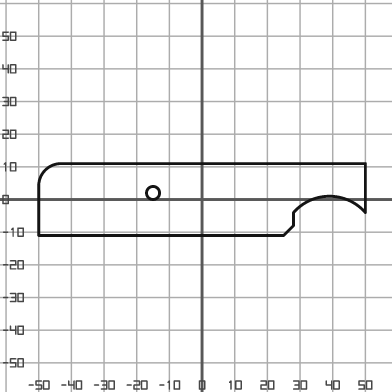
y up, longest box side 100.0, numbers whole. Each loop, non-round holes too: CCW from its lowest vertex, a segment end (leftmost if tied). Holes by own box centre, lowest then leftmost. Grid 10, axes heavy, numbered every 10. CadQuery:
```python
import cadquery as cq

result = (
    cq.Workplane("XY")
    .moveTo(-50.0, -11.0)
    .lineTo(25.0, -11.0)
    .lineTo(28.0, -8.0)
    .lineTo(28.0, -4.0)
    .threePointArc((39.0, 1.0), (50.0, -4.0))
    .lineTo(50.0, 11.0)
    .lineTo(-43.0, 11.0)
    .threePointArc((-48.0, 9.0), (-50.0, 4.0))
    .close()
    .moveTo(-15.0, 2.0)
    .circle(2.0)
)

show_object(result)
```